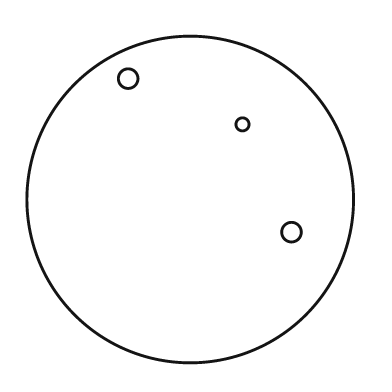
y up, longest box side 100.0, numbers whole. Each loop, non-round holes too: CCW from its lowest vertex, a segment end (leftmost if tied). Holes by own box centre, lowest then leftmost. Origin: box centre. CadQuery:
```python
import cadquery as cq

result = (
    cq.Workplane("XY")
    .moveTo(0.0, 0.0)
    .circle(50.0)
    .moveTo(31.0, -10.0)
    .circle(3.0)
    .moveTo(16.0, 23.0)
    .circle(2.0)
    .moveTo(-19.0, 37.0)
    .circle(3.0)
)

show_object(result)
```